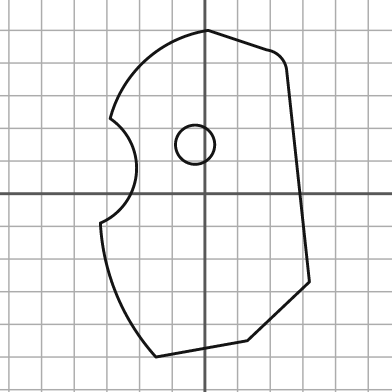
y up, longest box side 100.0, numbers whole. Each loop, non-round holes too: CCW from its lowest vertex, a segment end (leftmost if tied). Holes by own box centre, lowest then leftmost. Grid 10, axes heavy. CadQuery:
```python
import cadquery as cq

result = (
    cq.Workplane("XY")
    .moveTo(-15.0, -50.0)
    .lineTo(13.0, -45.0)
    .lineTo(32.0, -27.0)
    .lineTo(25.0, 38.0)
    .threePointArc((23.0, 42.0), (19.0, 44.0))
    .lineTo(1.0, 50.0)
    .threePointArc((-18.0, 41.0), (-29.0, 23.0))
    .threePointArc((-21.0, 6.0), (-32.0, -9.0))
    .threePointArc((-27.0, -31.0), (-15.0, -50.0))
    .close()
    .moveTo(-3.0, 15.0)
    .circle(6.0)
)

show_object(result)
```